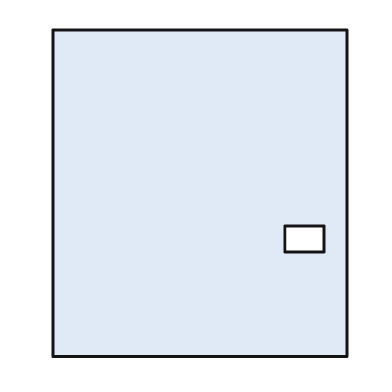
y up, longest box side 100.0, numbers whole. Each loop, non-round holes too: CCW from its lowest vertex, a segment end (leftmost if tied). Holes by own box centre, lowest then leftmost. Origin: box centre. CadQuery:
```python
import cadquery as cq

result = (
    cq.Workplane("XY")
    .moveTo(-45.0, -50.0)
    .lineTo(45.0, -50.0)
    .lineTo(45.0, 50.0)
    .lineTo(-45.0, 50.0)
    .close()
    .moveTo(26.0, -18.0)
    .lineTo(38.0, -18.0)
    .lineTo(38.0, -10.0)
    .lineTo(26.0, -10.0)
    .close()
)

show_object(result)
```